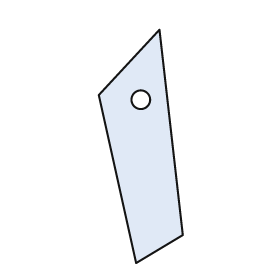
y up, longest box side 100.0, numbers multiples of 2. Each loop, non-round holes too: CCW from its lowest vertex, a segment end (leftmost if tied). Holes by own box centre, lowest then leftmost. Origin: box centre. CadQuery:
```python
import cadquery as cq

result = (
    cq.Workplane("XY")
    .moveTo(-2.0, -50.0)
    .lineTo(18.0, -38.0)
    .lineTo(8.0, 50.0)
    .lineTo(-18.0, 22.0)
    .close()
    .moveTo(0.0, 20.0)
    .circle(4.0)
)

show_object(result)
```